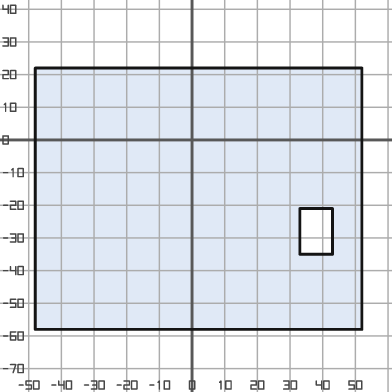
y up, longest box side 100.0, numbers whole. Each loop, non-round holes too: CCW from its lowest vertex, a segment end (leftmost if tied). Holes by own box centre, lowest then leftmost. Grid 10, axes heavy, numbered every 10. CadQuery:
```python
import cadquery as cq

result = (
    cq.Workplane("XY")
    .moveTo(-48.0, -58.0)
    .lineTo(52.0, -58.0)
    .lineTo(52.0, 22.0)
    .lineTo(-48.0, 22.0)
    .close()
    .moveTo(33.0, -35.0)
    .lineTo(43.0, -35.0)
    .lineTo(43.0, -21.0)
    .lineTo(33.0, -21.0)
    .close()
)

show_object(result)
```